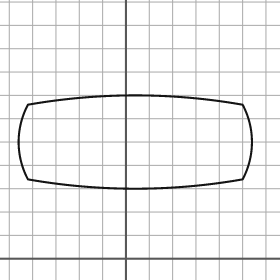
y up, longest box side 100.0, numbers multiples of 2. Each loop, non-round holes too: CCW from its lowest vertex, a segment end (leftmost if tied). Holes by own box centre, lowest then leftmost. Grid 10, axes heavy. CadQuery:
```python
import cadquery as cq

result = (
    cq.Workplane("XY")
    .moveTo(-42.0, 34.0)
    .threePointArc((4.0, 30.0), (50.0, 34.0))
    .threePointArc((54.0, 50.0), (50.0, 66.0))
    .threePointArc((4.0, 70.0), (-42.0, 66.0))
    .threePointArc((-46.0, 50.0), (-42.0, 34.0))
    .close()
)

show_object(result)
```